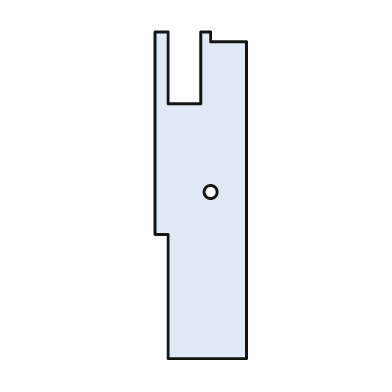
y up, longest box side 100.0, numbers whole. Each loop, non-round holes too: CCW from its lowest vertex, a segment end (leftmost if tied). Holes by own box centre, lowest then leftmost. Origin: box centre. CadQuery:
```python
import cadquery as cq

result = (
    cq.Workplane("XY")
    .moveTo(-10.0, -50.0)
    .lineTo(14.0, -50.0)
    .lineTo(14.0, 47.0)
    .lineTo(3.0, 47.0)
    .lineTo(3.0, 50.0)
    .lineTo(0.0, 50.0)
    .lineTo(0.0, 28.0)
    .lineTo(-10.0, 28.0)
    .lineTo(-10.0, 50.0)
    .lineTo(-14.0, 50.0)
    .lineTo(-14.0, -12.0)
    .lineTo(-10.0, -12.0)
    .close()
    .moveTo(3.0, 1.0)
    .circle(2.0)
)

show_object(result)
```